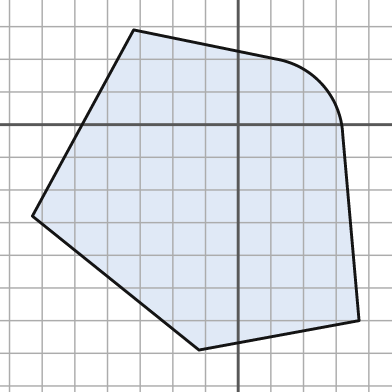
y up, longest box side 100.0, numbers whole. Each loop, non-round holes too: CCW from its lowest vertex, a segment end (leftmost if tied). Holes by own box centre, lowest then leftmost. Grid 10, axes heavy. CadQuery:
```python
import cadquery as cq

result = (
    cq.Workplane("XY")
    .moveTo(-12.0, -69.0)
    .lineTo(37.0, -60.0)
    .lineTo(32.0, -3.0)
    .threePointArc((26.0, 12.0), (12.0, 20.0))
    .lineTo(-32.0, 29.0)
    .lineTo(-63.0, -28.0)
    .close()
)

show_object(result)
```